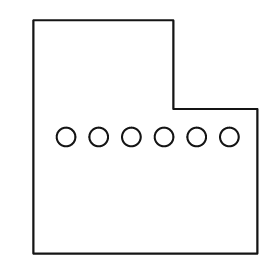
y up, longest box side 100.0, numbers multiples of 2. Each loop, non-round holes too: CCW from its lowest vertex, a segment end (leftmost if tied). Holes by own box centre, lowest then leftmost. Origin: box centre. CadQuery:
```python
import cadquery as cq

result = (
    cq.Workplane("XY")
    .moveTo(-48.0, -50.0)
    .lineTo(48.0, -50.0)
    .lineTo(48.0, 12.0)
    .lineTo(12.0, 12.0)
    .lineTo(12.0, 50.0)
    .lineTo(-48.0, 50.0)
    .close()
    .moveTo(-34.0, 0.0)
    .circle(4.0)
    .moveTo(-20.0, 0.0)
    .circle(4.0)
    .moveTo(-6.0, 0.0)
    .circle(4.0)
    .moveTo(8.0, 0.0)
    .circle(4.0)
    .moveTo(22.0, 0.0)
    .circle(4.0)
    .moveTo(36.0, 0.0)
    .circle(4.0)
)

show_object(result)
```